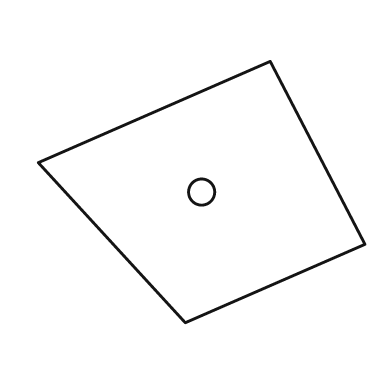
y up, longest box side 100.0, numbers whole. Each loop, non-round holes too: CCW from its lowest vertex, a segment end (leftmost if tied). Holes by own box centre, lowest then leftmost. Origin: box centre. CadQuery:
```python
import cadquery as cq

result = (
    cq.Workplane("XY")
    .moveTo(-5.0, -40.0)
    .lineTo(50.0, -16.0)
    .lineTo(21.0, 40.0)
    .lineTo(-50.0, 9.0)
    .close()
    .moveTo(0.0, 0.0)
    .circle(4.0)
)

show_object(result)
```